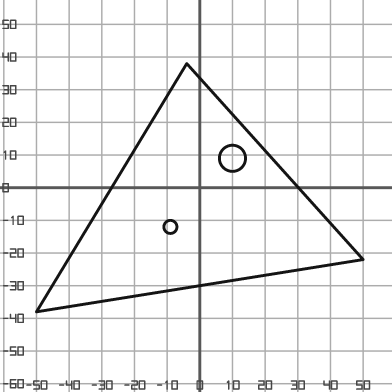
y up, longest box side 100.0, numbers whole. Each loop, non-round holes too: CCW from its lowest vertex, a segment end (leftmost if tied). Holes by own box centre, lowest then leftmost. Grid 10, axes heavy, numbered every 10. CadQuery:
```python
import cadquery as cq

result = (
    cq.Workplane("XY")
    .moveTo(-50.0, -38.0)
    .lineTo(50.0, -22.0)
    .lineTo(-4.0, 38.0)
    .close()
    .moveTo(-9.0, -12.0)
    .circle(2.0)
    .moveTo(10.0, 9.0)
    .circle(4.0)
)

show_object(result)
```